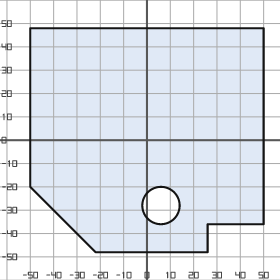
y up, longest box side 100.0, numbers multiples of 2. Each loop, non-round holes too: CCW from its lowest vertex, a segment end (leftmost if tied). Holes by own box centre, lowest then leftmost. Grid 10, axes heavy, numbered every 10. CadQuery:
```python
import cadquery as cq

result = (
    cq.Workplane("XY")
    .moveTo(-22.0, -48.0)
    .lineTo(26.0, -48.0)
    .lineTo(26.0, -36.0)
    .lineTo(50.0, -36.0)
    .lineTo(50.0, 48.0)
    .lineTo(-50.0, 48.0)
    .lineTo(-50.0, -20.0)
    .close()
    .moveTo(6.0, -28.0)
    .circle(8.0)
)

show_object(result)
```